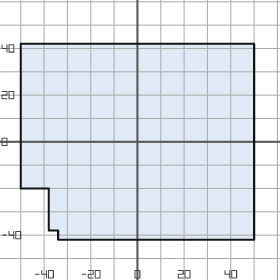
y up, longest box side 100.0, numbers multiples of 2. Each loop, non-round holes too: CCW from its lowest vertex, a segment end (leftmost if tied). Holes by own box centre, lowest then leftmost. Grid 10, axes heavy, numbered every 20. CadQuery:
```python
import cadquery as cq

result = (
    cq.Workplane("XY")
    .moveTo(-34.0, -42.0)
    .lineTo(50.0, -42.0)
    .lineTo(50.0, 42.0)
    .lineTo(-50.0, 42.0)
    .lineTo(-50.0, -20.0)
    .lineTo(-38.0, -20.0)
    .lineTo(-38.0, -38.0)
    .lineTo(-34.0, -38.0)
    .close()
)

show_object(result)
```